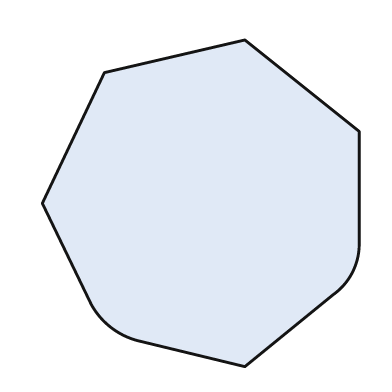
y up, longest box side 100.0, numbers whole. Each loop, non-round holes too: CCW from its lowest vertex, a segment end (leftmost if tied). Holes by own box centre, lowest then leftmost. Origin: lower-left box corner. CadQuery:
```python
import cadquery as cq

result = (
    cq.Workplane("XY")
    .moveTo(62.0, 0.0)
    .lineTo(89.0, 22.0)
    .threePointArc((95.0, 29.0), (97.0, 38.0))
    .lineTo(97.0, 72.0)
    .lineTo(62.0, 100.0)
    .lineTo(19.0, 90.0)
    .lineTo(0.0, 50.0)
    .lineTo(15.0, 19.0)
    .threePointArc((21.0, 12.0), (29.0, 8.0))
    .close()
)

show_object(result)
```